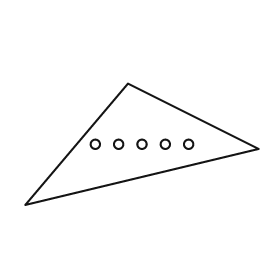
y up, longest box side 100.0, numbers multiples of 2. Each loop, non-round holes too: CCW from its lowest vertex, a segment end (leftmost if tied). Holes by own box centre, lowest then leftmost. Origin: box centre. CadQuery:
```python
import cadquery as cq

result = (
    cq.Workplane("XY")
    .moveTo(-50.0, -26.0)
    .lineTo(50.0, -2.0)
    .lineTo(-6.0, 26.0)
    .close()
    .moveTo(-20.0, 0.0)
    .circle(2.0)
    .moveTo(-10.0, 0.0)
    .circle(2.0)
    .moveTo(0.0, 0.0)
    .circle(2.0)
    .moveTo(10.0, 0.0)
    .circle(2.0)
    .moveTo(20.0, 0.0)
    .circle(2.0)
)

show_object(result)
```